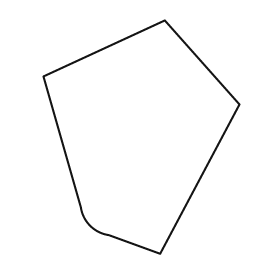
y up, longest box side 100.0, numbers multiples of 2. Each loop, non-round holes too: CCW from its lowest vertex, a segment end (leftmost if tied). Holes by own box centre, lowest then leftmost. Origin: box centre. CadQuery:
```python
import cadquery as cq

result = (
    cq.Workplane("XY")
    .moveTo(8.0, -50.0)
    .lineTo(42.0, 14.0)
    .lineTo(10.0, 50.0)
    .lineTo(-42.0, 26.0)
    .lineTo(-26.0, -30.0)
    .threePointArc((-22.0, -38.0), (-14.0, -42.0))
    .close()
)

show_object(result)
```